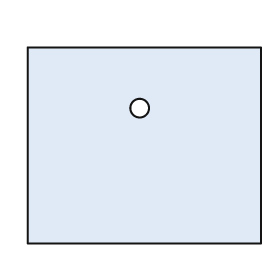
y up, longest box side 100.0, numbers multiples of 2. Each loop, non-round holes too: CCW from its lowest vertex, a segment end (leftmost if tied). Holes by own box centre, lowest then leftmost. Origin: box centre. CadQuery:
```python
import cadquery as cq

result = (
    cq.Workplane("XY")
    .moveTo(-50.0, -42.0)
    .lineTo(50.0, -42.0)
    .lineTo(50.0, 42.0)
    .lineTo(-50.0, 42.0)
    .close()
    .moveTo(-2.0, 16.0)
    .circle(4.0)
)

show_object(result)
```